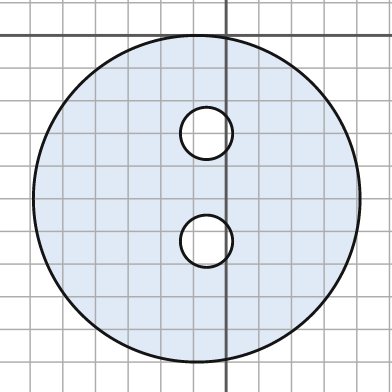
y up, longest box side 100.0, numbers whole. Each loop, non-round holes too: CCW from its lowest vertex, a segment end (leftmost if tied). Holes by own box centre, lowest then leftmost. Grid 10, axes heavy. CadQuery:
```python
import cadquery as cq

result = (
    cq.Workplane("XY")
    .moveTo(-9.0, -50.0)
    .circle(50.0)
    .moveTo(-6.0, -63.0)
    .circle(8.0)
    .moveTo(-6.0, -30.0)
    .circle(8.0)
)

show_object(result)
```